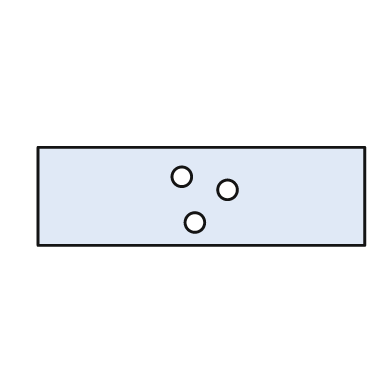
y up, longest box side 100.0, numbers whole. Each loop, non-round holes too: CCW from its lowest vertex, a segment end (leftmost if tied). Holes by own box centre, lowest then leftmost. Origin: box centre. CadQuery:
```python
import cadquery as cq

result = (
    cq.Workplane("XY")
    .moveTo(-50.0, -15.0)
    .lineTo(50.0, -15.0)
    .lineTo(50.0, 15.0)
    .lineTo(-50.0, 15.0)
    .close()
    .moveTo(-2.0, -8.0)
    .circle(3.0)
    .moveTo(8.0, 2.0)
    .circle(3.0)
    .moveTo(-6.0, 6.0)
    .circle(3.0)
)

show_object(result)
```